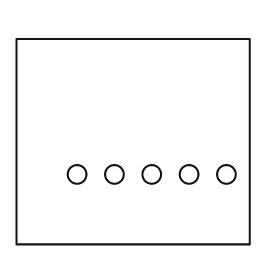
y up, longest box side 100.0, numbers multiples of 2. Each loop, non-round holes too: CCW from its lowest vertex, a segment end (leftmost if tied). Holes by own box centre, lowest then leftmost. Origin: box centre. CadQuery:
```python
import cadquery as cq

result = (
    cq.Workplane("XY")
    .moveTo(-50.0, -44.0)
    .lineTo(50.0, -44.0)
    .lineTo(50.0, 44.0)
    .lineTo(-50.0, 44.0)
    .close()
    .moveTo(-24.0, -14.0)
    .circle(4.0)
    .moveTo(-8.0, -14.0)
    .circle(4.0)
    .moveTo(8.0, -14.0)
    .circle(4.0)
    .moveTo(24.0, -14.0)
    .circle(4.0)
    .moveTo(40.0, -14.0)
    .circle(4.0)
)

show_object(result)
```